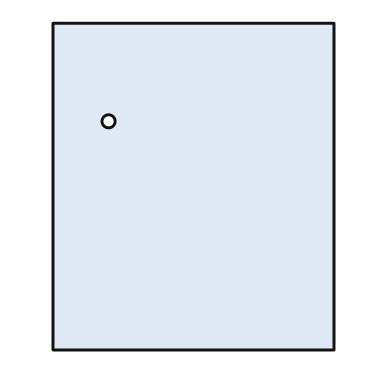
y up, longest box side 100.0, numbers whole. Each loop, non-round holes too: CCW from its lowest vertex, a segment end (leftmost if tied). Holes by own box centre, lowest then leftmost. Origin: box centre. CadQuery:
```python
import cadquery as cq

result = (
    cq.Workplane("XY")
    .moveTo(-43.0, -50.0)
    .lineTo(43.0, -50.0)
    .lineTo(43.0, 50.0)
    .lineTo(-43.0, 50.0)
    .close()
    .moveTo(-26.0, 20.0)
    .circle(2.0)
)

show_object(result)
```